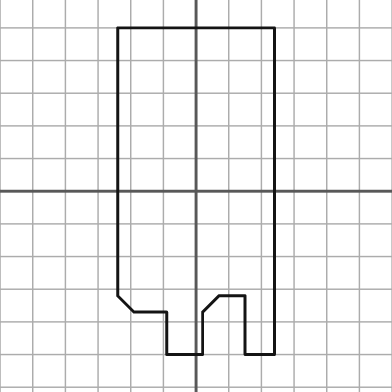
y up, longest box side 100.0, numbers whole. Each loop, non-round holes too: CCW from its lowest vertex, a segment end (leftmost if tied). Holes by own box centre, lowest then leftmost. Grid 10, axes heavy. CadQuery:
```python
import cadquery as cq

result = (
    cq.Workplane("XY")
    .moveTo(-9.0, -50.0)
    .lineTo(2.0, -50.0)
    .lineTo(2.0, -37.0)
    .lineTo(7.0, -32.0)
    .lineTo(15.0, -32.0)
    .lineTo(15.0, -50.0)
    .lineTo(24.0, -50.0)
    .lineTo(24.0, 50.0)
    .lineTo(-24.0, 50.0)
    .lineTo(-24.0, -32.0)
    .lineTo(-19.0, -37.0)
    .lineTo(-9.0, -37.0)
    .close()
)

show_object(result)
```